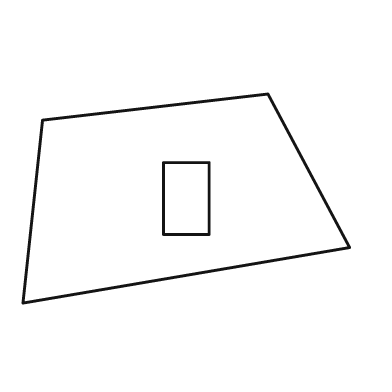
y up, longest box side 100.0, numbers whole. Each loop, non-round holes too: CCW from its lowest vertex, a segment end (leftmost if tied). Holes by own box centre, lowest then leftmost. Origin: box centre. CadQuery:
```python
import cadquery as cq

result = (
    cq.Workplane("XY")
    .moveTo(-50.0, -32.0)
    .lineTo(50.0, -15.0)
    .lineTo(25.0, 32.0)
    .lineTo(-44.0, 24.0)
    .close()
    .moveTo(-7.0, -11.0)
    .lineTo(7.0, -11.0)
    .lineTo(7.0, 11.0)
    .lineTo(-7.0, 11.0)
    .close()
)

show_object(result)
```